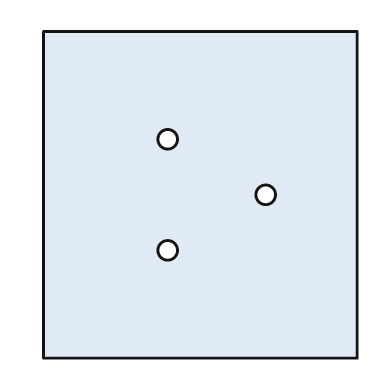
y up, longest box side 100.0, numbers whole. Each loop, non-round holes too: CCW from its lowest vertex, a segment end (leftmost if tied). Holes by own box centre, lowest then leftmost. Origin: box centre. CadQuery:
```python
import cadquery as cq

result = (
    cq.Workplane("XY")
    .moveTo(-48.0, -50.0)
    .lineTo(48.0, -50.0)
    .lineTo(48.0, 50.0)
    .lineTo(-48.0, 50.0)
    .close()
    .moveTo(-10.0, -17.0)
    .circle(3.0)
    .moveTo(20.0, 0.0)
    .circle(3.0)
    .moveTo(-10.0, 17.0)
    .circle(3.0)
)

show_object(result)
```